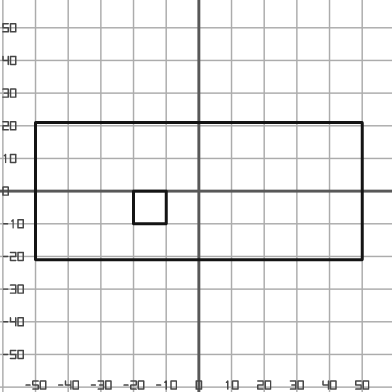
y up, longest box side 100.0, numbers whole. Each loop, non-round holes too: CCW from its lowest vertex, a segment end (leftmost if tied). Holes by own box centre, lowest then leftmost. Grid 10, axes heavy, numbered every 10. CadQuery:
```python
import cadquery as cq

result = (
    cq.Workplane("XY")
    .moveTo(-50.0, -21.0)
    .lineTo(50.0, -21.0)
    .lineTo(50.0, 21.0)
    .lineTo(-50.0, 21.0)
    .close()
    .moveTo(-20.0, -10.0)
    .lineTo(-10.0, -10.0)
    .lineTo(-10.0, 0.0)
    .lineTo(-20.0, 0.0)
    .close()
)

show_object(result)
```